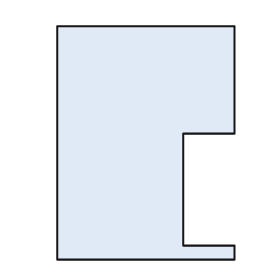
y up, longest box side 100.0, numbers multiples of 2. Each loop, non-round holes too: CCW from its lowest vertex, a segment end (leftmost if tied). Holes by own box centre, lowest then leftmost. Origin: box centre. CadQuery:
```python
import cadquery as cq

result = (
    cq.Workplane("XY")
    .moveTo(-38.0, -50.0)
    .lineTo(38.0, -50.0)
    .lineTo(38.0, -44.0)
    .lineTo(16.0, -44.0)
    .lineTo(16.0, 4.0)
    .lineTo(38.0, 4.0)
    .lineTo(38.0, 50.0)
    .lineTo(-38.0, 50.0)
    .close()
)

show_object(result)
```